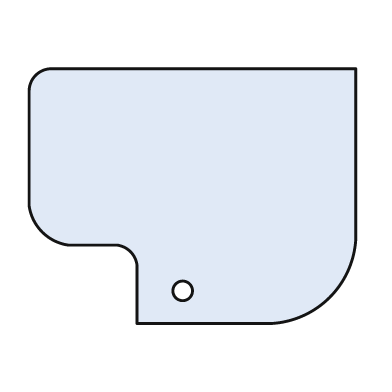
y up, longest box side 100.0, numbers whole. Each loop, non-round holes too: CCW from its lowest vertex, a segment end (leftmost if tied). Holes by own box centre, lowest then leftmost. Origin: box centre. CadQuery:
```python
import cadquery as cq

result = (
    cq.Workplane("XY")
    .moveTo(-17.0, -39.0)
    .lineTo(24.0, -39.0)
    .threePointArc((42.0, -31.0), (50.0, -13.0))
    .lineTo(50.0, 39.0)
    .lineTo(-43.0, 39.0)
    .threePointArc((-48.0, 37.0), (-50.0, 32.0))
    .lineTo(-50.0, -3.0)
    .threePointArc((-46.0, -11.0), (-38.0, -15.0))
    .lineTo(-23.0, -15.0)
    .threePointArc((-19.0, -17.0), (-17.0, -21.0))
    .close()
    .moveTo(-3.0, -29.0)
    .circle(3.0)
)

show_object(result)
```